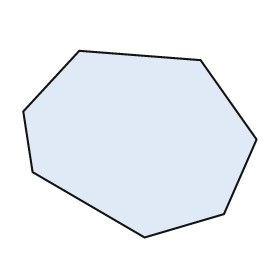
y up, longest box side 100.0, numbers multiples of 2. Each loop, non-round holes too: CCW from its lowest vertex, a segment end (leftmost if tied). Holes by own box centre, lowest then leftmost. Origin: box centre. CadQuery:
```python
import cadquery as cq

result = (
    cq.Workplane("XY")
    .moveTo(2.0, -40.0)
    .lineTo(36.0, -30.0)
    .lineTo(50.0, 2.0)
    .lineTo(26.0, 36.0)
    .lineTo(-26.0, 40.0)
    .lineTo(-50.0, 14.0)
    .lineTo(-46.0, -12.0)
    .close()
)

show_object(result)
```